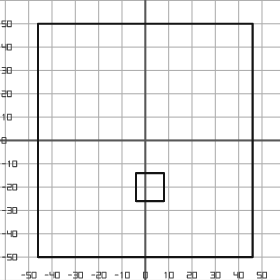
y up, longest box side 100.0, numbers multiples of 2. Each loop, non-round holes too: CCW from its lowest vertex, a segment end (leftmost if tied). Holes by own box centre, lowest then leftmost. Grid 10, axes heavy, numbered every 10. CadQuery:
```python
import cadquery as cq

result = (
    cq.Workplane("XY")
    .moveTo(-46.0, -50.0)
    .lineTo(46.0, -50.0)
    .lineTo(46.0, 50.0)
    .lineTo(-46.0, 50.0)
    .close()
    .moveTo(-4.0, -26.0)
    .lineTo(8.0, -26.0)
    .lineTo(8.0, -14.0)
    .lineTo(-4.0, -14.0)
    .close()
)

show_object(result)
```